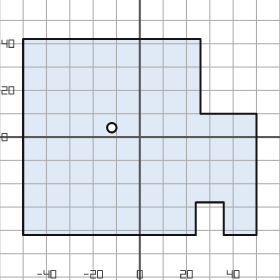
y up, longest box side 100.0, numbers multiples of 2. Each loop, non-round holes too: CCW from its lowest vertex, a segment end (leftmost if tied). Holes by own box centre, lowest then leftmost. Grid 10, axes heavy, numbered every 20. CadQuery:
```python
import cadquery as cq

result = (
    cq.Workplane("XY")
    .moveTo(-50.0, -42.0)
    .lineTo(24.0, -42.0)
    .lineTo(24.0, -28.0)
    .lineTo(36.0, -28.0)
    .lineTo(36.0, -42.0)
    .lineTo(50.0, -42.0)
    .lineTo(50.0, 10.0)
    .lineTo(26.0, 10.0)
    .lineTo(26.0, 42.0)
    .lineTo(-50.0, 42.0)
    .close()
    .moveTo(-12.0, 4.0)
    .circle(2.0)
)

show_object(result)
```